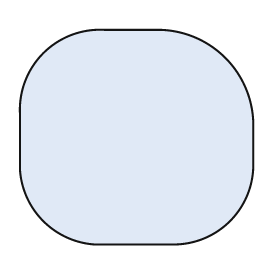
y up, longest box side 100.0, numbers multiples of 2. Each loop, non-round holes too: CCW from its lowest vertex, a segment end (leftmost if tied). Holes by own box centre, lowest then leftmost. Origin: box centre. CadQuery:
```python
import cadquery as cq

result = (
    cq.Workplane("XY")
    .moveTo(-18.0, -46.0)
    .lineTo(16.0, -46.0)
    .threePointArc((40.0, -36.0), (50.0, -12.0))
    .lineTo(50.0, 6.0)
    .threePointArc((38.0, 34.0), (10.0, 46.0))
    .lineTo(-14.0, 46.0)
    .threePointArc((-40.0, 36.0), (-50.0, 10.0))
    .lineTo(-50.0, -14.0)
    .threePointArc((-40.0, -36.0), (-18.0, -46.0))
    .close()
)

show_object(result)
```